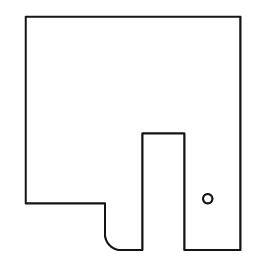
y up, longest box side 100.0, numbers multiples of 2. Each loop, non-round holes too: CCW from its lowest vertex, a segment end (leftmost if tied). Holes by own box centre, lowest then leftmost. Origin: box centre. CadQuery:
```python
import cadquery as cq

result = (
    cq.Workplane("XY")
    .moveTo(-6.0, -50.0)
    .lineTo(4.0, -50.0)
    .lineTo(4.0, 0.0)
    .lineTo(22.0, 0.0)
    .lineTo(22.0, -50.0)
    .lineTo(46.0, -50.0)
    .lineTo(46.0, 50.0)
    .lineTo(-46.0, 50.0)
    .lineTo(-46.0, -30.0)
    .lineTo(-12.0, -30.0)
    .lineTo(-12.0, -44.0)
    .threePointArc((-10.0, -48.0), (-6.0, -50.0))
    .close()
    .moveTo(32.0, -28.0)
    .circle(2.0)
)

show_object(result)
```